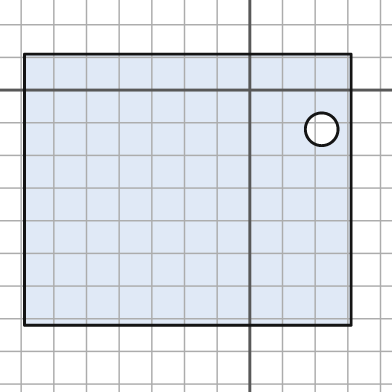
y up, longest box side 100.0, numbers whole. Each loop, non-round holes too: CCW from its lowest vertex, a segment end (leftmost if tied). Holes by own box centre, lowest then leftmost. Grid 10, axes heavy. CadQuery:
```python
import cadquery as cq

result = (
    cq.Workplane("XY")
    .moveTo(-69.0, -72.0)
    .lineTo(31.0, -72.0)
    .lineTo(31.0, 11.0)
    .lineTo(-69.0, 11.0)
    .close()
    .moveTo(22.0, -12.0)
    .circle(5.0)
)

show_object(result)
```